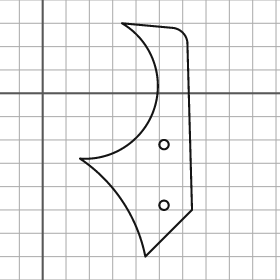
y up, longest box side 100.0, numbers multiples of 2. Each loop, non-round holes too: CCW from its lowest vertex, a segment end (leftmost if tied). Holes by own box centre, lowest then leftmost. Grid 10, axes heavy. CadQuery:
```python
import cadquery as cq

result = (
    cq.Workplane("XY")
    .moveTo(44.0, -70.0)
    .lineTo(64.0, -50.0)
    .lineTo(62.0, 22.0)
    .threePointArc((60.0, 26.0), (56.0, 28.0))
    .lineTo(34.0, 30.0)
    .threePointArc((48.0, -6.0), (16.0, -28.0))
    .threePointArc((34.0, -46.0), (44.0, -70.0))
    .close()
    .moveTo(52.0, -48.0)
    .circle(2.0)
    .moveTo(52.0, -22.0)
    .circle(2.0)
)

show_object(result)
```